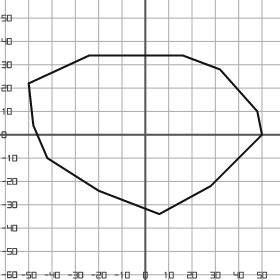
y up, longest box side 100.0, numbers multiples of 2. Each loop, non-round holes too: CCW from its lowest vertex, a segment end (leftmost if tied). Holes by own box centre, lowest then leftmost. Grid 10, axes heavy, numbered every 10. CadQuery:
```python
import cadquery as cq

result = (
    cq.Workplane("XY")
    .moveTo(6.0, -34.0)
    .lineTo(28.0, -22.0)
    .lineTo(50.0, 0.0)
    .lineTo(48.0, 10.0)
    .lineTo(32.0, 28.0)
    .lineTo(16.0, 34.0)
    .lineTo(-24.0, 34.0)
    .lineTo(-50.0, 22.0)
    .lineTo(-48.0, 4.0)
    .lineTo(-42.0, -10.0)
    .lineTo(-20.0, -24.0)
    .close()
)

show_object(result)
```